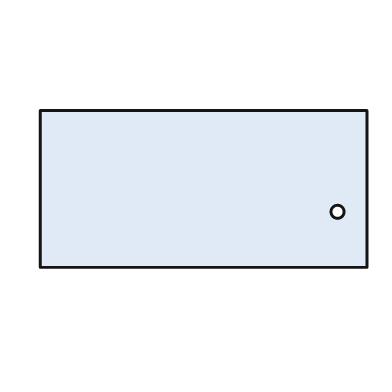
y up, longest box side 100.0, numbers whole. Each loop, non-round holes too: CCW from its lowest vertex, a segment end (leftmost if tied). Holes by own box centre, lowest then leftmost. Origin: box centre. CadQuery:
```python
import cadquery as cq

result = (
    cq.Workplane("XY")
    .moveTo(-50.0, -24.0)
    .lineTo(50.0, -24.0)
    .lineTo(50.0, 24.0)
    .lineTo(-50.0, 24.0)
    .close()
    .moveTo(41.0, -7.0)
    .circle(2.0)
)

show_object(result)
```